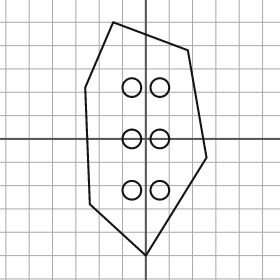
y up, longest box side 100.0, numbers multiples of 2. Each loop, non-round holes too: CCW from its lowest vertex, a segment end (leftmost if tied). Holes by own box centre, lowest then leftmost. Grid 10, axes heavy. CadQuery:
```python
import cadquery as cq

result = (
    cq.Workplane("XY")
    .moveTo(0.0, -50.0)
    .lineTo(26.0, -8.0)
    .lineTo(18.0, 38.0)
    .lineTo(-14.0, 50.0)
    .lineTo(-26.0, 22.0)
    .lineTo(-24.0, -28.0)
    .close()
    .moveTo(-6.0, -22.0)
    .circle(4.0)
    .moveTo(6.0, -22.0)
    .circle(4.0)
    .moveTo(-6.0, 0.0)
    .circle(4.0)
    .moveTo(6.0, 0.0)
    .circle(4.0)
    .moveTo(-6.0, 22.0)
    .circle(4.0)
    .moveTo(6.0, 22.0)
    .circle(4.0)
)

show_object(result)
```